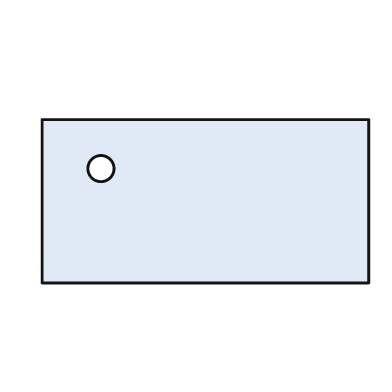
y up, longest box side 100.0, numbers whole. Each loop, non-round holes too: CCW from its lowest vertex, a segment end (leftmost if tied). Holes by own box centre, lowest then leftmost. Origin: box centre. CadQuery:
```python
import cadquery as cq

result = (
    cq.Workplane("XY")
    .moveTo(-50.0, -25.0)
    .lineTo(50.0, -25.0)
    .lineTo(50.0, 25.0)
    .lineTo(-50.0, 25.0)
    .close()
    .moveTo(-32.0, 10.0)
    .circle(4.0)
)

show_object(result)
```